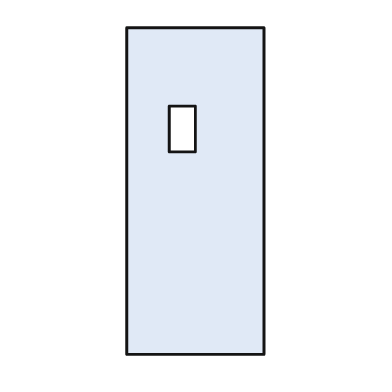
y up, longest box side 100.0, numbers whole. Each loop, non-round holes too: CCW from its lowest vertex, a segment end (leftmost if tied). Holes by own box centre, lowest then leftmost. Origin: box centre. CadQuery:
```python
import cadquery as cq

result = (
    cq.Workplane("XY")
    .moveTo(-21.0, -50.0)
    .lineTo(21.0, -50.0)
    .lineTo(21.0, 50.0)
    .lineTo(-21.0, 50.0)
    .close()
    .moveTo(-8.0, 12.0)
    .lineTo(0.0, 12.0)
    .lineTo(0.0, 26.0)
    .lineTo(-8.0, 26.0)
    .close()
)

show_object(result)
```